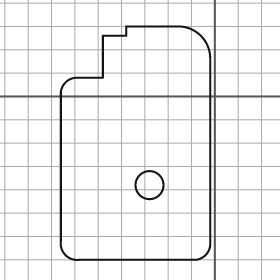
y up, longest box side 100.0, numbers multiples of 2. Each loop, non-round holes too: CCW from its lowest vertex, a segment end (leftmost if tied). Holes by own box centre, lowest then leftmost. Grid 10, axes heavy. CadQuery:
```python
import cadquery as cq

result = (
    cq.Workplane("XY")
    .moveTo(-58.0, -70.0)
    .lineTo(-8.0, -70.0)
    .threePointArc((-4.0, -68.0), (-2.0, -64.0))
    .lineTo(-2.0, 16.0)
    .threePointArc((-6.0, 26.0), (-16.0, 30.0))
    .lineTo(-38.0, 30.0)
    .lineTo(-38.0, 26.0)
    .lineTo(-48.0, 26.0)
    .lineTo(-48.0, 8.0)
    .lineTo(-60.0, 8.0)
    .threePointArc((-64.0, 6.0), (-66.0, 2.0))
    .lineTo(-66.0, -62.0)
    .threePointArc((-64.0, -68.0), (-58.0, -70.0))
    .close()
    .moveTo(-28.0, -38.0)
    .circle(6.0)
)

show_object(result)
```